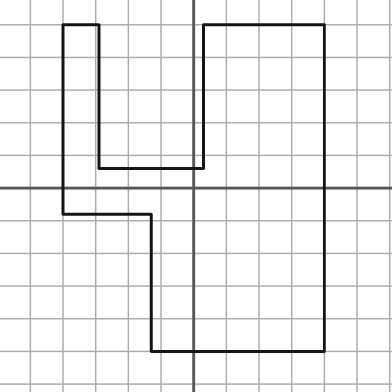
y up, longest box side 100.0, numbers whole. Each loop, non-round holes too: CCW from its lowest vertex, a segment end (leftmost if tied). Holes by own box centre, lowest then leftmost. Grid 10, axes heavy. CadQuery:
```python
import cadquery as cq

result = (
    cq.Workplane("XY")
    .moveTo(-13.0, -50.0)
    .lineTo(40.0, -50.0)
    .lineTo(40.0, 50.0)
    .lineTo(3.0, 50.0)
    .lineTo(3.0, 6.0)
    .lineTo(-29.0, 6.0)
    .lineTo(-29.0, 50.0)
    .lineTo(-40.0, 50.0)
    .lineTo(-40.0, -8.0)
    .lineTo(-13.0, -8.0)
    .close()
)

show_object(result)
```